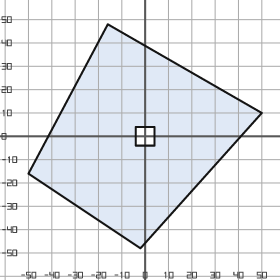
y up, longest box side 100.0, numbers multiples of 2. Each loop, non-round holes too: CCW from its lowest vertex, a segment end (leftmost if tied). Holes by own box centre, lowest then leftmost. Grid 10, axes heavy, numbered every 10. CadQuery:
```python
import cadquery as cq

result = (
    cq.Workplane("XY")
    .moveTo(-2.0, -48.0)
    .lineTo(50.0, 10.0)
    .lineTo(-16.0, 48.0)
    .lineTo(-50.0, -16.0)
    .close()
    .moveTo(-4.0, -4.0)
    .lineTo(4.0, -4.0)
    .lineTo(4.0, 4.0)
    .lineTo(-4.0, 4.0)
    .close()
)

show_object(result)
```